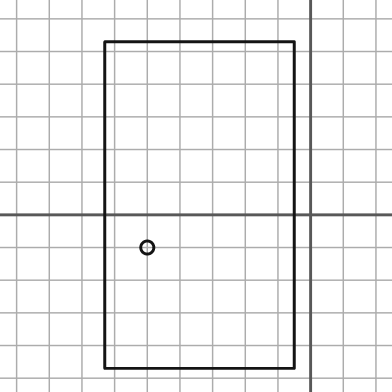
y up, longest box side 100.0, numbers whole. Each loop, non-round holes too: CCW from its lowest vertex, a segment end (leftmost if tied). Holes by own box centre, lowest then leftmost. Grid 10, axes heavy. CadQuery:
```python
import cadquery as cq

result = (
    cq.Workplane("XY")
    .moveTo(-63.0, -47.0)
    .lineTo(-5.0, -47.0)
    .lineTo(-5.0, 53.0)
    .lineTo(-63.0, 53.0)
    .close()
    .moveTo(-50.0, -10.0)
    .circle(2.0)
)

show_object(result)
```